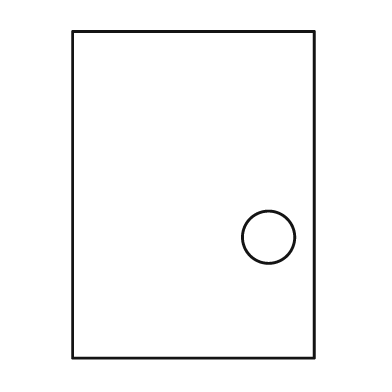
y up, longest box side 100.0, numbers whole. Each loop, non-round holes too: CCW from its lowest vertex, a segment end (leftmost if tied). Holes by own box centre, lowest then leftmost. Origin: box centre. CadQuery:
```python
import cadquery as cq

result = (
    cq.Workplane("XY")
    .moveTo(-37.0, -50.0)
    .lineTo(37.0, -50.0)
    .lineTo(37.0, 50.0)
    .lineTo(-37.0, 50.0)
    .close()
    .moveTo(23.0, -13.0)
    .circle(8.0)
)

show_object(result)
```